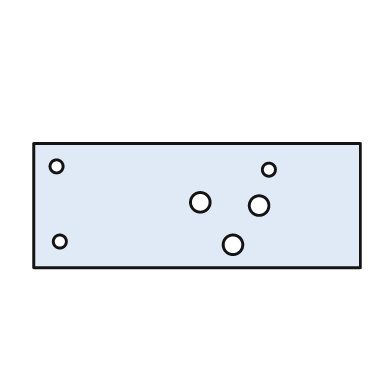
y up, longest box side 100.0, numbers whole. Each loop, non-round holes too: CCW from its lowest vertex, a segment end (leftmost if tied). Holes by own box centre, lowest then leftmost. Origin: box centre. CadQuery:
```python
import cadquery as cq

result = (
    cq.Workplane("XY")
    .moveTo(-50.0, -19.0)
    .lineTo(50.0, -19.0)
    .lineTo(50.0, 19.0)
    .lineTo(-50.0, 19.0)
    .close()
    .moveTo(11.0, -12.0)
    .circle(3.0)
    .moveTo(-42.0, -11.0)
    .circle(2.0)
    .moveTo(19.0, 0.0)
    .circle(3.0)
    .moveTo(1.0, 1.0)
    .circle(3.0)
    .moveTo(22.0, 11.0)
    .circle(2.0)
    .moveTo(-43.0, 12.0)
    .circle(2.0)
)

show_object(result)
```